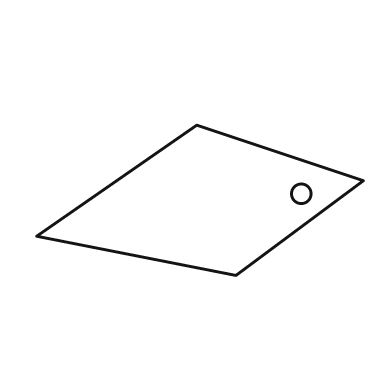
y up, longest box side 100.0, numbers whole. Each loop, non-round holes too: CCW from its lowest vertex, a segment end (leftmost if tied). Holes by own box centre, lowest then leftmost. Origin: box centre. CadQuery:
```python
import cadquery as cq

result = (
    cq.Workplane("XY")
    .moveTo(11.0, -23.0)
    .lineTo(50.0, 6.0)
    .lineTo(-1.0, 23.0)
    .lineTo(-50.0, -11.0)
    .close()
    .moveTo(31.0, 2.0)
    .circle(3.0)
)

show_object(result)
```